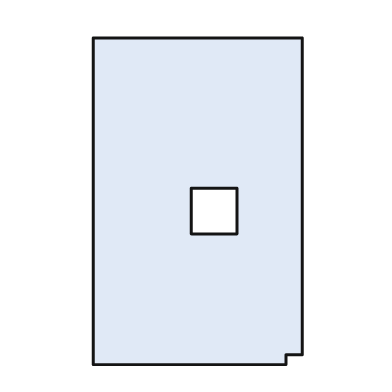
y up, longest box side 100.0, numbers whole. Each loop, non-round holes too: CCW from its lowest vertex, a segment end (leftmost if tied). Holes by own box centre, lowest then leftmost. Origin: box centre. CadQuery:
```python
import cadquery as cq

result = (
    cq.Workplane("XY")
    .moveTo(-32.0, -50.0)
    .lineTo(27.0, -50.0)
    .lineTo(27.0, -47.0)
    .lineTo(32.0, -47.0)
    .lineTo(32.0, 50.0)
    .lineTo(-32.0, 50.0)
    .close()
    .moveTo(-2.0, -10.0)
    .lineTo(12.0, -10.0)
    .lineTo(12.0, 4.0)
    .lineTo(-2.0, 4.0)
    .close()
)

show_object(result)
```